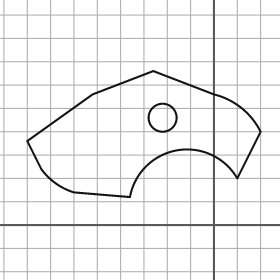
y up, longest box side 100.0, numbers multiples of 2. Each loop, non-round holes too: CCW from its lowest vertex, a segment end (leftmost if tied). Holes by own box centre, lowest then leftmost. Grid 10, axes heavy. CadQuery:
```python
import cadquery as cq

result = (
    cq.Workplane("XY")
    .moveTo(-36.0, 12.0)
    .threePointArc((-16.0, 32.0), (10.0, 20.0))
    .lineTo(20.0, 40.0)
    .threePointArc((12.0, 50.0), (0.0, 56.0))
    .lineTo(-26.0, 66.0)
    .lineTo(-52.0, 56.0)
    .lineTo(-80.0, 36.0)
    .lineTo(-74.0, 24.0)
    .threePointArc((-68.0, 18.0), (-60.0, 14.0))
    .close()
    .moveTo(-22.0, 46.0)
    .circle(6.0)
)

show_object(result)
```